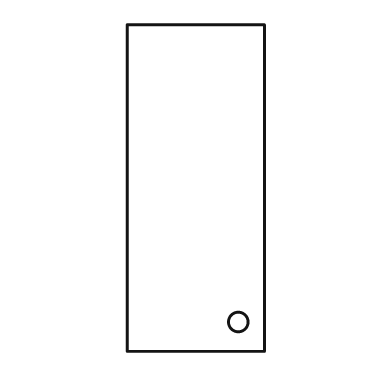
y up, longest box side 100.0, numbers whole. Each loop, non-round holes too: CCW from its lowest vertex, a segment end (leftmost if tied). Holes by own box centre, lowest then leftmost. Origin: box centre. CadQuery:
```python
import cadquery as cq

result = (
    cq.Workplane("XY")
    .moveTo(-21.0, -50.0)
    .lineTo(21.0, -50.0)
    .lineTo(21.0, 50.0)
    .lineTo(-21.0, 50.0)
    .close()
    .moveTo(13.0, -41.0)
    .circle(3.0)
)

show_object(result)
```